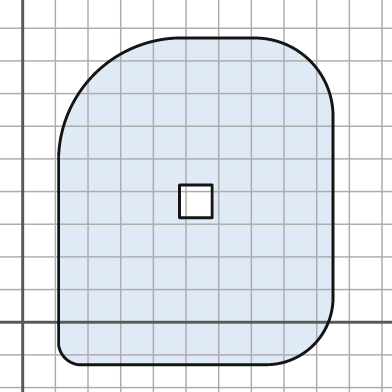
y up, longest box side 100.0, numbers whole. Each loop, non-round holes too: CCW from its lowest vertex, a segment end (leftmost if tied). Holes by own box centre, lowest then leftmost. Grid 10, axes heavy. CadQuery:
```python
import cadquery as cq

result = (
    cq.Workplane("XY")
    .moveTo(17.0, -13.0)
    .lineTo(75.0, -13.0)
    .threePointArc((89.0, -7.0), (95.0, 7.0))
    .lineTo(95.0, 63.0)
    .threePointArc((88.0, 80.0), (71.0, 87.0))
    .lineTo(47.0, 87.0)
    .threePointArc((22.0, 76.0), (11.0, 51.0))
    .lineTo(11.0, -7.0)
    .threePointArc((13.0, -11.0), (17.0, -13.0))
    .close()
    .moveTo(48.0, 32.0)
    .lineTo(58.0, 32.0)
    .lineTo(58.0, 42.0)
    .lineTo(48.0, 42.0)
    .close()
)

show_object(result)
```